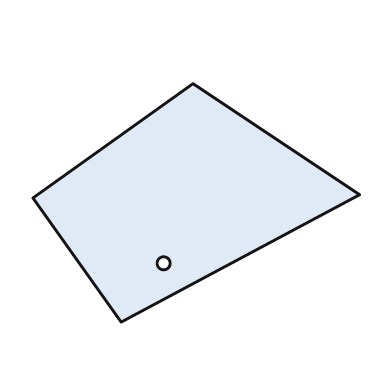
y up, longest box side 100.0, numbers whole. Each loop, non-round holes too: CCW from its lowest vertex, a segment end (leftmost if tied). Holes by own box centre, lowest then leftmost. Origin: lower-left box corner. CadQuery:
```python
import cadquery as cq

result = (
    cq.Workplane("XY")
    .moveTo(27.0, 0.0)
    .lineTo(100.0, 39.0)
    .lineTo(49.0, 73.0)
    .lineTo(0.0, 38.0)
    .close()
    .moveTo(40.0, 18.0)
    .circle(2.0)
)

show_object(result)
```